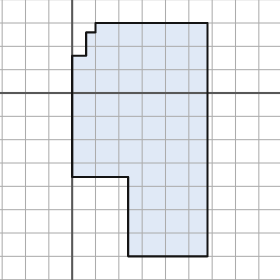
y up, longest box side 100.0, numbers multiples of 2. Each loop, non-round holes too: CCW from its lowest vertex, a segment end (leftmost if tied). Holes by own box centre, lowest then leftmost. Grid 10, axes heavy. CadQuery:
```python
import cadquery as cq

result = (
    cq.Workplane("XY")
    .moveTo(24.0, -70.0)
    .lineTo(58.0, -70.0)
    .lineTo(58.0, 30.0)
    .lineTo(10.0, 30.0)
    .lineTo(10.0, 26.0)
    .lineTo(6.0, 26.0)
    .lineTo(6.0, 16.0)
    .lineTo(0.0, 16.0)
    .lineTo(0.0, -36.0)
    .lineTo(24.0, -36.0)
    .close()
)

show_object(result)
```